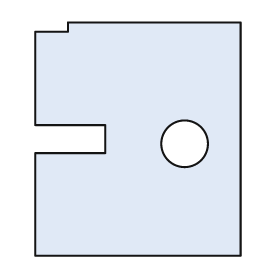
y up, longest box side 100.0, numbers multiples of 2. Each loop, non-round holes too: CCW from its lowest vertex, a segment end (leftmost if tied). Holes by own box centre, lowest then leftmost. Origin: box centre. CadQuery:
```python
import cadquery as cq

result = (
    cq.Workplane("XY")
    .moveTo(-44.0, -50.0)
    .lineTo(44.0, -50.0)
    .lineTo(44.0, 50.0)
    .lineTo(-30.0, 50.0)
    .lineTo(-30.0, 46.0)
    .lineTo(-44.0, 46.0)
    .lineTo(-44.0, 6.0)
    .lineTo(-14.0, 6.0)
    .lineTo(-14.0, -6.0)
    .lineTo(-44.0, -6.0)
    .close()
    .moveTo(20.0, -2.0)
    .circle(10.0)
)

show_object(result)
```